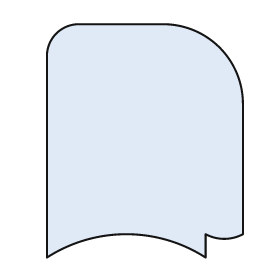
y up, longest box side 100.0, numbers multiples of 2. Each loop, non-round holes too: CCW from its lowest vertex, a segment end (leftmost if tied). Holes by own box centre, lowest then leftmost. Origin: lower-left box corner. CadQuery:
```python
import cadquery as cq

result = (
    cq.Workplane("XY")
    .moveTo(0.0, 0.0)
    .threePointArc((34.0, 10.0), (68.0, 0.0))
    .lineTo(68.0, 10.0)
    .threePointArc((76.0, 8.0), (84.0, 10.0))
    .lineTo(84.0, 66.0)
    .threePointArc((74.0, 90.0), (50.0, 100.0))
    .lineTo(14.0, 100.0)
    .threePointArc((4.0, 96.0), (0.0, 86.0))
    .close()
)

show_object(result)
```